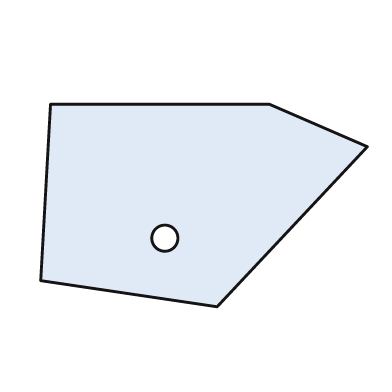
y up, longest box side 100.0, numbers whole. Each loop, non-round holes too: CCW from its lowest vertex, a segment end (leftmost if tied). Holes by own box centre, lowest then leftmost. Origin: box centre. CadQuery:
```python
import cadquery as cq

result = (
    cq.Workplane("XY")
    .moveTo(4.0, -31.0)
    .lineTo(50.0, 18.0)
    .lineTo(20.0, 31.0)
    .lineTo(-47.0, 31.0)
    .lineTo(-50.0, -23.0)
    .close()
    .moveTo(-12.0, -10.0)
    .circle(4.0)
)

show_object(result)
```